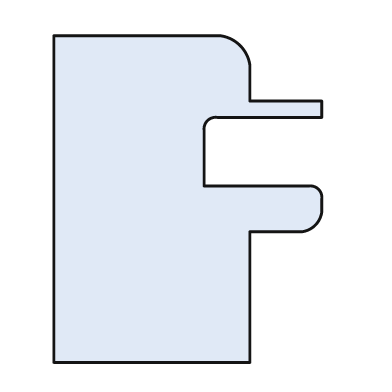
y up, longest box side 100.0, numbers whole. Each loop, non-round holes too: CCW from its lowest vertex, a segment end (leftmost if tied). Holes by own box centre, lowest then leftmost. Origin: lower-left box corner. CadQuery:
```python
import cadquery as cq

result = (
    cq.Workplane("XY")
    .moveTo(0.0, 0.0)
    .lineTo(60.0, 0.0)
    .lineTo(60.0, 40.0)
    .lineTo(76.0, 40.0)
    .threePointArc((80.0, 42.0), (82.0, 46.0))
    .lineTo(82.0, 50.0)
    .threePointArc((81.0, 53.0), (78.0, 54.0))
    .lineTo(46.0, 54.0)
    .lineTo(46.0, 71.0)
    .threePointArc((47.0, 74.0), (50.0, 75.0))
    .lineTo(82.0, 75.0)
    .lineTo(82.0, 80.0)
    .lineTo(60.0, 80.0)
    .lineTo(60.0, 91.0)
    .threePointArc((57.0, 97.0), (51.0, 100.0))
    .lineTo(0.0, 100.0)
    .close()
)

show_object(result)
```